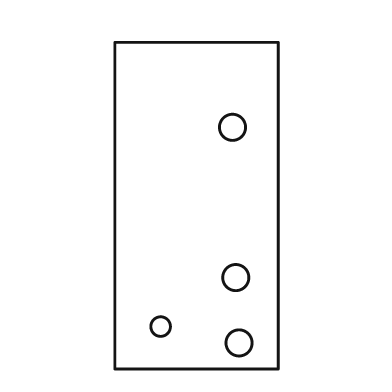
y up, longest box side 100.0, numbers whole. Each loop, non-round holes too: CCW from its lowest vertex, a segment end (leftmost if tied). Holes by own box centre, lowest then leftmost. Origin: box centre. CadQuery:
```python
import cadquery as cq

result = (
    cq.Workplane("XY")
    .moveTo(-25.0, -50.0)
    .lineTo(25.0, -50.0)
    .lineTo(25.0, 50.0)
    .lineTo(-25.0, 50.0)
    .close()
    .moveTo(13.0, -42.0)
    .circle(4.0)
    .moveTo(-11.0, -37.0)
    .circle(3.0)
    .moveTo(12.0, -22.0)
    .circle(4.0)
    .moveTo(11.0, 24.0)
    .circle(4.0)
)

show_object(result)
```